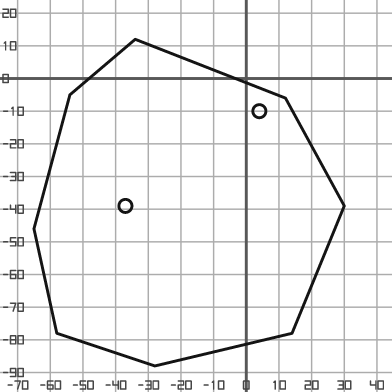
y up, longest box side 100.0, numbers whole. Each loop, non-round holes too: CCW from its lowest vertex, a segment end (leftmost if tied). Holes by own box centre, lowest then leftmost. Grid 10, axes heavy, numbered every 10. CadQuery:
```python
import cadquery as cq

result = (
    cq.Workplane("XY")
    .moveTo(-28.0, -88.0)
    .lineTo(14.0, -78.0)
    .lineTo(30.0, -39.0)
    .lineTo(12.0, -6.0)
    .lineTo(-34.0, 12.0)
    .lineTo(-54.0, -5.0)
    .lineTo(-65.0, -46.0)
    .lineTo(-58.0, -78.0)
    .close()
    .moveTo(-37.0, -39.0)
    .circle(2.0)
    .moveTo(4.0, -10.0)
    .circle(2.0)
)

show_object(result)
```